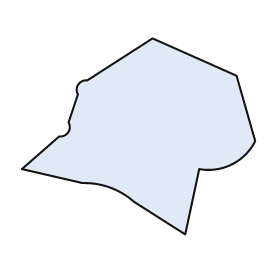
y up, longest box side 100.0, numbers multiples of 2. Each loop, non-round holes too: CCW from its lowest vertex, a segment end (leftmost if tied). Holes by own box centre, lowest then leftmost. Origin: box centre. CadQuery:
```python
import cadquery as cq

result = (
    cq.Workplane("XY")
    .moveTo(20.0, -42.0)
    .lineTo(26.0, -14.0)
    .threePointArc((40.0, -12.0), (50.0, -2.0))
    .lineTo(42.0, 26.0)
    .lineTo(6.0, 42.0)
    .lineTo(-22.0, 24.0)
    .threePointArc((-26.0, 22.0), (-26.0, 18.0))
    .lineTo(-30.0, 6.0)
    .threePointArc((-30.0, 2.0), (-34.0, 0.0))
    .lineTo(-50.0, -14.0)
    .lineTo(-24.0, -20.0)
    .threePointArc((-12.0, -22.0), (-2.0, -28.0))
    .close()
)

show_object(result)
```